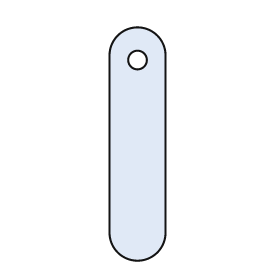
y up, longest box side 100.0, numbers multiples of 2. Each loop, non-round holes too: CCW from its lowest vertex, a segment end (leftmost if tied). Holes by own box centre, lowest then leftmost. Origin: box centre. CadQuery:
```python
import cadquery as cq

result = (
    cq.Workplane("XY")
    .moveTo(-12.0, -38.0)
    .threePointArc((0.0, -50.0), (12.0, -38.0))
    .lineTo(12.0, 38.0)
    .threePointArc((0.0, 50.0), (-12.0, 38.0))
    .close()
    .moveTo(0.0, 36.0)
    .circle(4.0)
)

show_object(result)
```